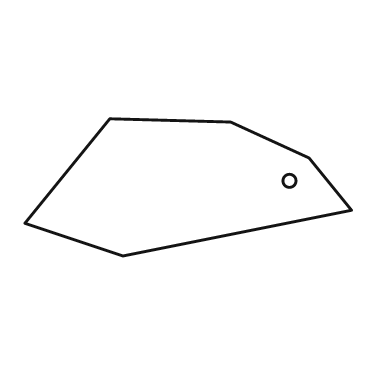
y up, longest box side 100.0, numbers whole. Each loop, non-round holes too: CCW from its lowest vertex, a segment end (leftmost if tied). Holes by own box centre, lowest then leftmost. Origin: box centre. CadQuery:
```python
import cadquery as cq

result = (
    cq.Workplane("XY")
    .moveTo(-20.0, -21.0)
    .lineTo(50.0, -7.0)
    .lineTo(37.0, 9.0)
    .lineTo(13.0, 20.0)
    .lineTo(-24.0, 21.0)
    .lineTo(-50.0, -11.0)
    .close()
    .moveTo(31.0, 2.0)
    .circle(2.0)
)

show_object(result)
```